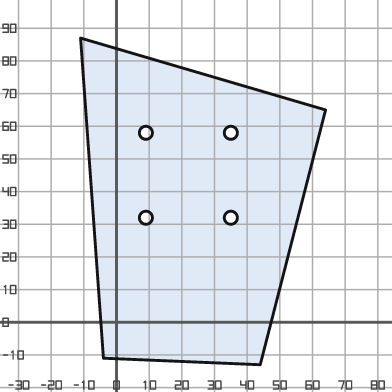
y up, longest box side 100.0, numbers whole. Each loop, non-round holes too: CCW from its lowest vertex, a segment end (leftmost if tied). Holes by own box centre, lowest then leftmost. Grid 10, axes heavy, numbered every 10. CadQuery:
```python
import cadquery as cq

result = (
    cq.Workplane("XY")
    .moveTo(44.0, -13.0)
    .lineTo(64.0, 65.0)
    .lineTo(-11.0, 87.0)
    .lineTo(-4.0, -11.0)
    .close()
    .moveTo(9.0, 32.0)
    .circle(2.0)
    .moveTo(35.0, 32.0)
    .circle(2.0)
    .moveTo(9.0, 58.0)
    .circle(2.0)
    .moveTo(35.0, 58.0)
    .circle(2.0)
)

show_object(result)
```